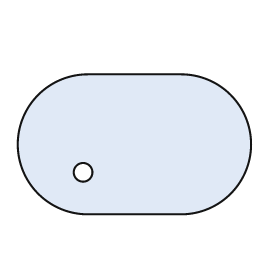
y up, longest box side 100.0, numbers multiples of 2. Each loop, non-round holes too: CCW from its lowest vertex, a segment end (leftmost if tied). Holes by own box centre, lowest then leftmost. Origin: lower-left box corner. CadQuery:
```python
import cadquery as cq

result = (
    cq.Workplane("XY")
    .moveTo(30.0, 0.0)
    .lineTo(70.0, 0.0)
    .threePointArc((100.0, 30.0), (70.0, 60.0))
    .lineTo(30.0, 60.0)
    .threePointArc((0.0, 30.0), (30.0, 0.0))
    .close()
    .moveTo(28.0, 18.0)
    .circle(4.0)
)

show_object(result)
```